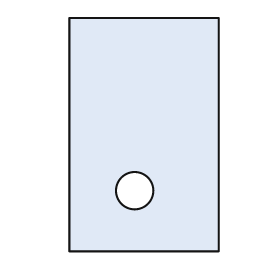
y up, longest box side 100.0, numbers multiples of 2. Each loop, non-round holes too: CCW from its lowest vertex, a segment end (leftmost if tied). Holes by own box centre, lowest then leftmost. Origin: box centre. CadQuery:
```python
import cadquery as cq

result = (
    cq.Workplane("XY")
    .moveTo(-32.0, -50.0)
    .lineTo(32.0, -50.0)
    .lineTo(32.0, 50.0)
    .lineTo(-32.0, 50.0)
    .close()
    .moveTo(-4.0, -24.0)
    .circle(8.0)
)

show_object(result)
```